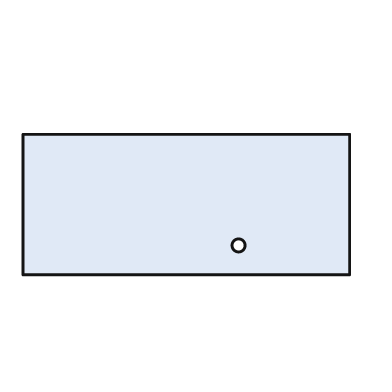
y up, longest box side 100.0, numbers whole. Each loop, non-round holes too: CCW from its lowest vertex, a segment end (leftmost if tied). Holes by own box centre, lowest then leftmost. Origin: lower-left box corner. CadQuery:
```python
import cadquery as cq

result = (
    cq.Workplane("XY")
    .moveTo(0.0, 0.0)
    .lineTo(100.0, 0.0)
    .lineTo(100.0, 43.0)
    .lineTo(0.0, 43.0)
    .close()
    .moveTo(66.0, 9.0)
    .circle(2.0)
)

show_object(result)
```